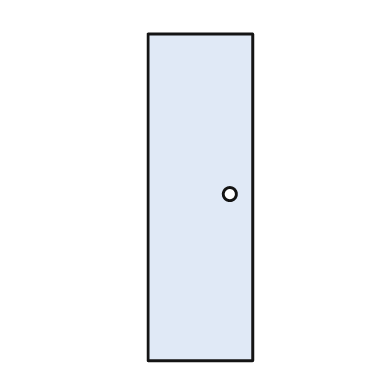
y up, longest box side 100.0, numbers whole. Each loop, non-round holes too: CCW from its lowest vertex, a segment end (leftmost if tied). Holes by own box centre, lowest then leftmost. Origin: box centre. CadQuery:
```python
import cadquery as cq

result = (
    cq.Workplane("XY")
    .moveTo(-16.0, -50.0)
    .lineTo(16.0, -50.0)
    .lineTo(16.0, 50.0)
    .lineTo(-16.0, 50.0)
    .close()
    .moveTo(9.0, 1.0)
    .circle(2.0)
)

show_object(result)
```